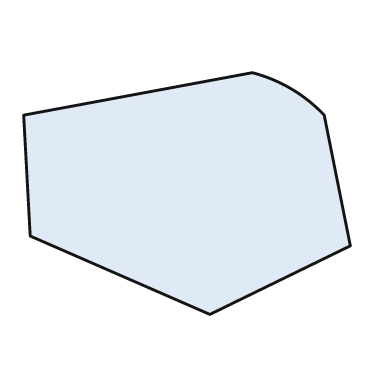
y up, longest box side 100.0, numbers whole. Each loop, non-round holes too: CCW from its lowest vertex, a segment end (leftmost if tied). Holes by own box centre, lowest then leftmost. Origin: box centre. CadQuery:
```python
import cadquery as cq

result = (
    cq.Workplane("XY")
    .moveTo(7.0, -37.0)
    .lineTo(50.0, -16.0)
    .lineTo(42.0, 24.0)
    .threePointArc((32.0, 32.0), (20.0, 37.0))
    .lineTo(-50.0, 24.0)
    .lineTo(-48.0, -13.0)
    .close()
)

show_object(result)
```